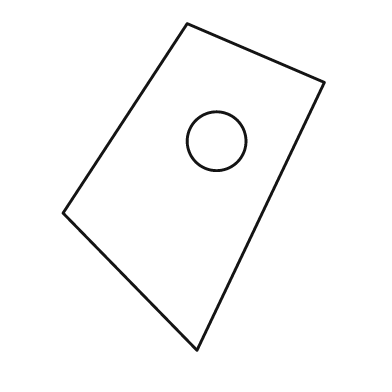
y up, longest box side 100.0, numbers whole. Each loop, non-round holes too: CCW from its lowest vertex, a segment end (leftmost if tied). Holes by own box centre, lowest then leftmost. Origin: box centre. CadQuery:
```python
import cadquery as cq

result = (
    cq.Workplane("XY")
    .moveTo(1.0, -50.0)
    .lineTo(40.0, 32.0)
    .lineTo(-2.0, 50.0)
    .lineTo(-40.0, -8.0)
    .close()
    .moveTo(7.0, 14.0)
    .circle(9.0)
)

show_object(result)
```